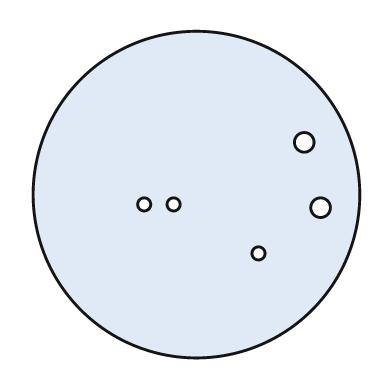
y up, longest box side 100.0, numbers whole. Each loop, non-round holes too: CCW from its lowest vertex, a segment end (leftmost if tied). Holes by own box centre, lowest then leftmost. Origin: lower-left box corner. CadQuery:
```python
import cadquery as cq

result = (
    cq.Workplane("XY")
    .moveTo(50.0, 50.0)
    .circle(50.0)
    .moveTo(69.0, 32.0)
    .circle(2.0)
    .moveTo(88.0, 46.0)
    .circle(3.0)
    .moveTo(34.0, 47.0)
    .circle(2.0)
    .moveTo(43.0, 47.0)
    .circle(2.0)
    .moveTo(83.0, 66.0)
    .circle(3.0)
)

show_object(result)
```